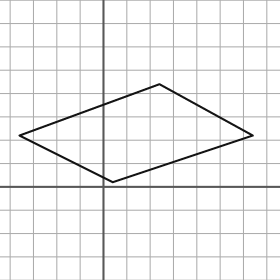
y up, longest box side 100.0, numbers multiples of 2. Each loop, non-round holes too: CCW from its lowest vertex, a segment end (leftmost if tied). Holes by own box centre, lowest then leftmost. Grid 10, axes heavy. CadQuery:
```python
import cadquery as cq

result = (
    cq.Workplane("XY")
    .moveTo(4.0, 2.0)
    .lineTo(64.0, 22.0)
    .lineTo(24.0, 44.0)
    .lineTo(-36.0, 22.0)
    .close()
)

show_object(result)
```